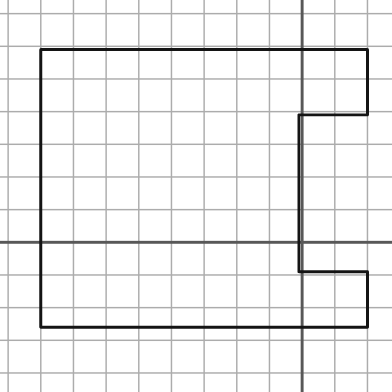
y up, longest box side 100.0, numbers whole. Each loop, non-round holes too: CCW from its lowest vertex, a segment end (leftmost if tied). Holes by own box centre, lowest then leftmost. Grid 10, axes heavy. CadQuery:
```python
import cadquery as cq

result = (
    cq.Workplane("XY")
    .moveTo(-80.0, -26.0)
    .lineTo(20.0, -26.0)
    .lineTo(20.0, -9.0)
    .lineTo(-1.0, -9.0)
    .lineTo(-1.0, 39.0)
    .lineTo(20.0, 39.0)
    .lineTo(20.0, 59.0)
    .lineTo(-80.0, 59.0)
    .close()
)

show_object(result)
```